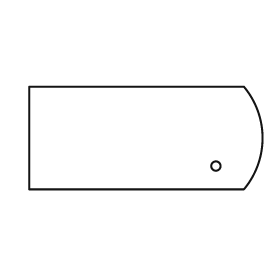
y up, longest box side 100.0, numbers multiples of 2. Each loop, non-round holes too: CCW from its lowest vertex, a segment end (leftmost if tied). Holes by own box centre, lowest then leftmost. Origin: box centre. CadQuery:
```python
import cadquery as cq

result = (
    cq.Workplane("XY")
    .moveTo(-50.0, -22.0)
    .lineTo(42.0, -22.0)
    .threePointArc((50.0, 0.0), (42.0, 22.0))
    .lineTo(-50.0, 22.0)
    .close()
    .moveTo(30.0, -12.0)
    .circle(2.0)
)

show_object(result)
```